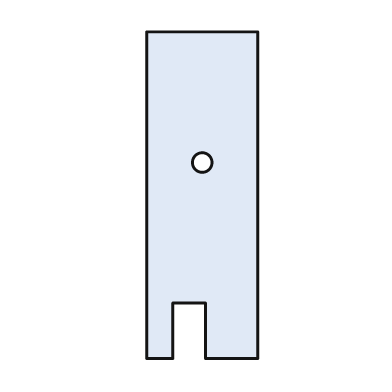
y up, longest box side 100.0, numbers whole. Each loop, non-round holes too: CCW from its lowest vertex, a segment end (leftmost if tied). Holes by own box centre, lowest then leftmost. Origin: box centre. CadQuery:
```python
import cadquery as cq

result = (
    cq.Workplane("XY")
    .moveTo(-17.0, -50.0)
    .lineTo(-9.0, -50.0)
    .lineTo(-9.0, -33.0)
    .lineTo(1.0, -33.0)
    .lineTo(1.0, -50.0)
    .lineTo(17.0, -50.0)
    .lineTo(17.0, 50.0)
    .lineTo(-17.0, 50.0)
    .close()
    .moveTo(0.0, 10.0)
    .circle(3.0)
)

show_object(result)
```